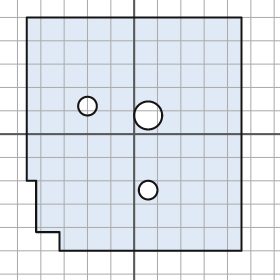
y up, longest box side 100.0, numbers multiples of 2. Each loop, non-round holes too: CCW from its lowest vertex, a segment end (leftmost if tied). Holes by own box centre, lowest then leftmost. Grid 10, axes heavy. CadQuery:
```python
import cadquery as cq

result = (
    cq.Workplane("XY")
    .moveTo(-32.0, -50.0)
    .lineTo(46.0, -50.0)
    .lineTo(46.0, 50.0)
    .lineTo(-46.0, 50.0)
    .lineTo(-46.0, -20.0)
    .lineTo(-42.0, -20.0)
    .lineTo(-42.0, -42.0)
    .lineTo(-32.0, -42.0)
    .close()
    .moveTo(6.0, -24.0)
    .circle(4.0)
    .moveTo(6.0, 8.0)
    .circle(6.0)
    .moveTo(-20.0, 12.0)
    .circle(4.0)
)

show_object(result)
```